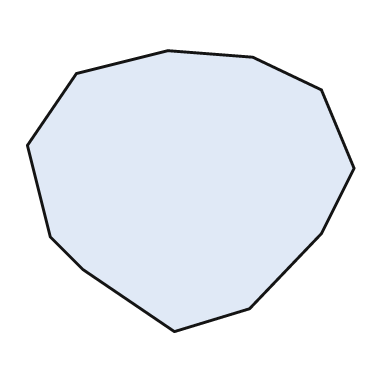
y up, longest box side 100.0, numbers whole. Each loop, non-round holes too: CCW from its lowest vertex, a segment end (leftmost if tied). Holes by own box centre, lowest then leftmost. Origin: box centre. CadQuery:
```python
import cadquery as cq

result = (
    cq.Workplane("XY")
    .moveTo(-5.0, -43.0)
    .lineTo(18.0, -36.0)
    .lineTo(40.0, -13.0)
    .lineTo(50.0, 7.0)
    .lineTo(40.0, 31.0)
    .lineTo(19.0, 41.0)
    .lineTo(-7.0, 43.0)
    .lineTo(-35.0, 36.0)
    .lineTo(-50.0, 14.0)
    .lineTo(-43.0, -14.0)
    .lineTo(-33.0, -24.0)
    .close()
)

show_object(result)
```